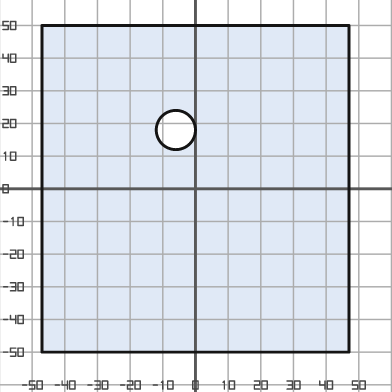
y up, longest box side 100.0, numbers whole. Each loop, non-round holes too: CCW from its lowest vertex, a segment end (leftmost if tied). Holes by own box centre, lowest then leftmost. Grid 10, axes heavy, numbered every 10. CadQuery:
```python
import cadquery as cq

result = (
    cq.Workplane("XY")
    .moveTo(-47.0, -50.0)
    .lineTo(47.0, -50.0)
    .lineTo(47.0, 50.0)
    .lineTo(-47.0, 50.0)
    .close()
    .moveTo(-6.0, 18.0)
    .circle(6.0)
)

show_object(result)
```